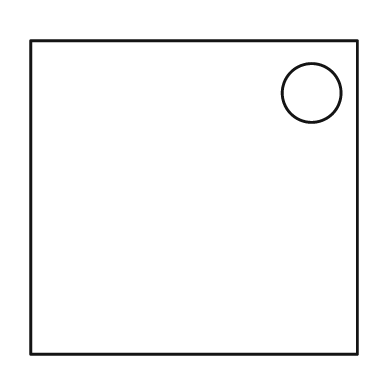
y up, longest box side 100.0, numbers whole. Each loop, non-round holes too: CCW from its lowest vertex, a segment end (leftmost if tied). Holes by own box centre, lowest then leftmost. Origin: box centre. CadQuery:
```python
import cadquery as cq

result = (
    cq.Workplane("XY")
    .moveTo(-50.0, -48.0)
    .lineTo(50.0, -48.0)
    .lineTo(50.0, 48.0)
    .lineTo(-50.0, 48.0)
    .close()
    .moveTo(36.0, 32.0)
    .circle(9.0)
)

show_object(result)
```